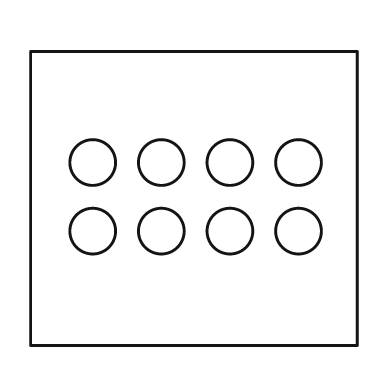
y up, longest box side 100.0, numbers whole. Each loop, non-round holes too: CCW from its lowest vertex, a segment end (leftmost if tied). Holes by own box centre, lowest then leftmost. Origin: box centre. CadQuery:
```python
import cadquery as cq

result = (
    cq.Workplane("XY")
    .moveTo(-50.0, -45.0)
    .lineTo(50.0, -45.0)
    .lineTo(50.0, 45.0)
    .lineTo(-50.0, 45.0)
    .close()
    .moveTo(-31.0, -10.0)
    .circle(7.0)
    .moveTo(-10.0, -10.0)
    .circle(7.0)
    .moveTo(11.0, -10.0)
    .circle(7.0)
    .moveTo(32.0, -10.0)
    .circle(7.0)
    .moveTo(-31.0, 11.0)
    .circle(7.0)
    .moveTo(-10.0, 11.0)
    .circle(7.0)
    .moveTo(11.0, 11.0)
    .circle(7.0)
    .moveTo(32.0, 11.0)
    .circle(7.0)
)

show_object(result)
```